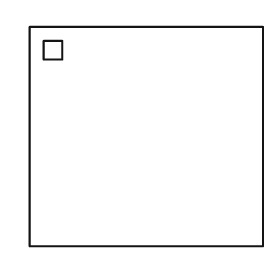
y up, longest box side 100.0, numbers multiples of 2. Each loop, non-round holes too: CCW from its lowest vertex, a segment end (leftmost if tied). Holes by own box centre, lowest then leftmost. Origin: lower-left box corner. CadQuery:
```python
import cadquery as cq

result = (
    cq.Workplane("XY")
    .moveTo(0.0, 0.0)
    .lineTo(100.0, 0.0)
    .lineTo(100.0, 94.0)
    .lineTo(0.0, 94.0)
    .close()
    .moveTo(6.0, 80.0)
    .lineTo(14.0, 80.0)
    .lineTo(14.0, 88.0)
    .lineTo(6.0, 88.0)
    .close()
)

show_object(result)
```